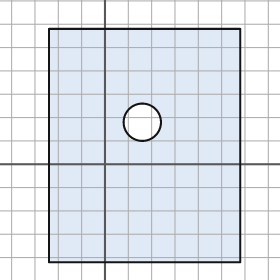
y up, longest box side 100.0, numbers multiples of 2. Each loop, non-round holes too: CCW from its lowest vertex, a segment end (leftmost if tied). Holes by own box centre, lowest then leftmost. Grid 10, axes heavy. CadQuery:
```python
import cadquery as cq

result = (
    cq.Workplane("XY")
    .moveTo(-24.0, -42.0)
    .lineTo(58.0, -42.0)
    .lineTo(58.0, 58.0)
    .lineTo(-24.0, 58.0)
    .close()
    .moveTo(16.0, 18.0)
    .circle(8.0)
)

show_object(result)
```